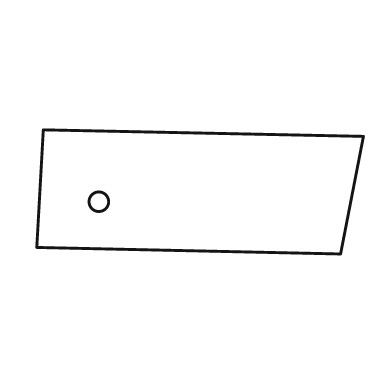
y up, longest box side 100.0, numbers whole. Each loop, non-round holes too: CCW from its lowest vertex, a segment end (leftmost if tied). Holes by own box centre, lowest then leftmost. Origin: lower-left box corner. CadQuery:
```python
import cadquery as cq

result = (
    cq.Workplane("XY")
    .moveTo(93.0, 0.0)
    .lineTo(100.0, 36.0)
    .lineTo(2.0, 38.0)
    .lineTo(0.0, 2.0)
    .close()
    .moveTo(19.0, 16.0)
    .circle(3.0)
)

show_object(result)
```